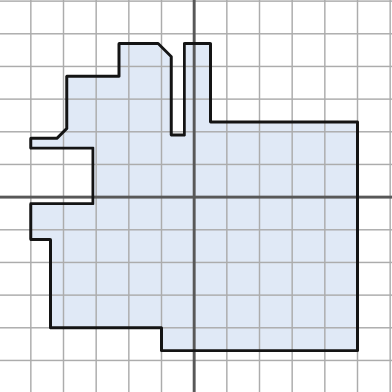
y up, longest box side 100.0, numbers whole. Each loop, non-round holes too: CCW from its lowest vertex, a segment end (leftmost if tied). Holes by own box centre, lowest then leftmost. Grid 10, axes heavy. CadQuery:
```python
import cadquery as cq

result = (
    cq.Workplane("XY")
    .moveTo(-10.0, -47.0)
    .lineTo(50.0, -47.0)
    .lineTo(50.0, 23.0)
    .lineTo(5.0, 23.0)
    .lineTo(5.0, 47.0)
    .lineTo(-3.0, 47.0)
    .lineTo(-3.0, 19.0)
    .lineTo(-7.0, 19.0)
    .lineTo(-7.0, 43.0)
    .lineTo(-11.0, 47.0)
    .lineTo(-23.0, 47.0)
    .lineTo(-23.0, 37.0)
    .lineTo(-39.0, 37.0)
    .lineTo(-39.0, 21.0)
    .lineTo(-42.0, 18.0)
    .lineTo(-50.0, 18.0)
    .lineTo(-50.0, 15.0)
    .lineTo(-31.0, 15.0)
    .lineTo(-31.0, -2.0)
    .lineTo(-50.0, -2.0)
    .lineTo(-50.0, -13.0)
    .lineTo(-44.0, -13.0)
    .lineTo(-44.0, -40.0)
    .lineTo(-10.0, -40.0)
    .close()
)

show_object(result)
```